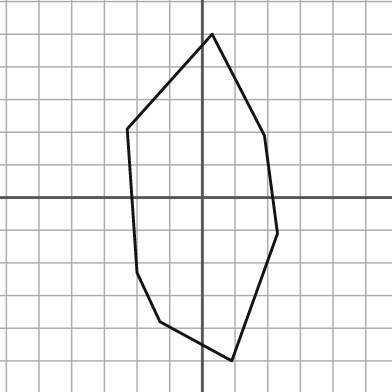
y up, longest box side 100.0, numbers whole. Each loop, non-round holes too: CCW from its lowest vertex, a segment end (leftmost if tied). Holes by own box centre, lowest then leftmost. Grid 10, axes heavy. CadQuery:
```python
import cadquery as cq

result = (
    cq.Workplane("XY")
    .moveTo(9.0, -50.0)
    .lineTo(23.0, -11.0)
    .lineTo(19.0, 19.0)
    .lineTo(3.0, 50.0)
    .lineTo(-23.0, 21.0)
    .lineTo(-20.0, -23.0)
    .lineTo(-13.0, -38.0)
    .close()
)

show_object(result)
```